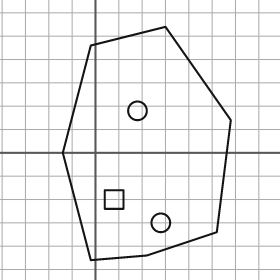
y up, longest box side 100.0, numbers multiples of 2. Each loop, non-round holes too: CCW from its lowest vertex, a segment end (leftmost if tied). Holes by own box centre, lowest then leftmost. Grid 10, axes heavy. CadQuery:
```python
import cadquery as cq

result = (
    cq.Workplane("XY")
    .moveTo(-2.0, -46.0)
    .lineTo(22.0, -44.0)
    .lineTo(52.0, -34.0)
    .lineTo(58.0, 14.0)
    .lineTo(30.0, 54.0)
    .lineTo(-2.0, 46.0)
    .lineTo(-14.0, 0.0)
    .close()
    .moveTo(28.0, -30.0)
    .circle(4.0)
    .moveTo(4.0, -24.0)
    .lineTo(12.0, -24.0)
    .lineTo(12.0, -16.0)
    .lineTo(4.0, -16.0)
    .close()
    .moveTo(18.0, 18.0)
    .circle(4.0)
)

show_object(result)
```